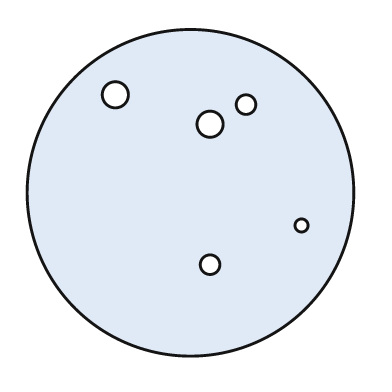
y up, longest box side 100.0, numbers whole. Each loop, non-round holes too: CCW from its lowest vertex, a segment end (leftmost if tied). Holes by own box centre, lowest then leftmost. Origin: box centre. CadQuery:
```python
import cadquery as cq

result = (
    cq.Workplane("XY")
    .moveTo(0.0, 0.0)
    .circle(50.0)
    .moveTo(6.0, -22.0)
    .circle(3.0)
    .moveTo(34.0, -10.0)
    .circle(2.0)
    .moveTo(6.0, 21.0)
    .circle(4.0)
    .moveTo(17.0, 27.0)
    .circle(3.0)
    .moveTo(-23.0, 30.0)
    .circle(4.0)
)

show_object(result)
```